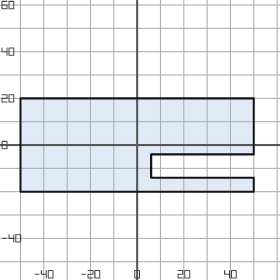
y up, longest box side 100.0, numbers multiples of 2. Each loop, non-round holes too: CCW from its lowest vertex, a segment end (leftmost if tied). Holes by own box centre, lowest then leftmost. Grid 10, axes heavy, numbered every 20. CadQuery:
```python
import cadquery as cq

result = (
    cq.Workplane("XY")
    .moveTo(-50.0, -20.0)
    .lineTo(50.0, -20.0)
    .lineTo(50.0, -14.0)
    .lineTo(6.0, -14.0)
    .lineTo(6.0, -4.0)
    .lineTo(50.0, -4.0)
    .lineTo(50.0, 20.0)
    .lineTo(-50.0, 20.0)
    .close()
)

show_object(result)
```